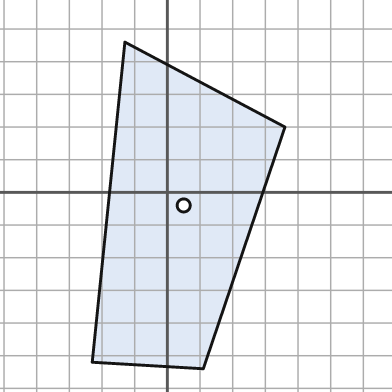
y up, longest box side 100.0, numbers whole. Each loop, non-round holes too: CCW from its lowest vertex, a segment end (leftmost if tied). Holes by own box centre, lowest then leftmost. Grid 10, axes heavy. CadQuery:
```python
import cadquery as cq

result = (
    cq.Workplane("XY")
    .moveTo(11.0, -54.0)
    .lineTo(36.0, 20.0)
    .lineTo(-13.0, 46.0)
    .lineTo(-23.0, -52.0)
    .close()
    .moveTo(5.0, -4.0)
    .circle(2.0)
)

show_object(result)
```